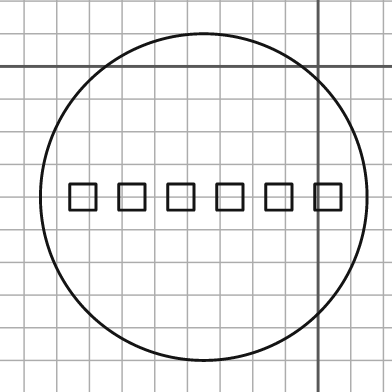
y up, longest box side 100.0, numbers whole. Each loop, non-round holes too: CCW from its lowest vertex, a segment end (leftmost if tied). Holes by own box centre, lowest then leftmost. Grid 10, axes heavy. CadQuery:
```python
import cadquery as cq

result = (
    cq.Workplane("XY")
    .moveTo(-35.0, -40.0)
    .circle(50.0)
    .moveTo(-76.0, -44.0)
    .lineTo(-68.0, -44.0)
    .lineTo(-68.0, -36.0)
    .lineTo(-76.0, -36.0)
    .close()
    .moveTo(-61.0, -44.0)
    .lineTo(-53.0, -44.0)
    .lineTo(-53.0, -36.0)
    .lineTo(-61.0, -36.0)
    .close()
    .moveTo(-46.0, -44.0)
    .lineTo(-38.0, -44.0)
    .lineTo(-38.0, -36.0)
    .lineTo(-46.0, -36.0)
    .close()
    .moveTo(-31.0, -44.0)
    .lineTo(-23.0, -44.0)
    .lineTo(-23.0, -36.0)
    .lineTo(-31.0, -36.0)
    .close()
    .moveTo(-16.0, -44.0)
    .lineTo(-8.0, -44.0)
    .lineTo(-8.0, -36.0)
    .lineTo(-16.0, -36.0)
    .close()
    .moveTo(-1.0, -44.0)
    .lineTo(7.0, -44.0)
    .lineTo(7.0, -36.0)
    .lineTo(-1.0, -36.0)
    .close()
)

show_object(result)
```